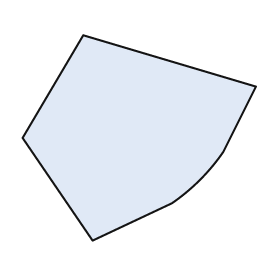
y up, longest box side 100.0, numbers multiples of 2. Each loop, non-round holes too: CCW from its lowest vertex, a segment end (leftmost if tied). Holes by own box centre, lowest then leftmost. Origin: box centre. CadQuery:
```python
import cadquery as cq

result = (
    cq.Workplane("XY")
    .moveTo(-20.0, -44.0)
    .lineTo(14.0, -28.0)
    .threePointArc((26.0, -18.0), (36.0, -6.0))
    .lineTo(50.0, 22.0)
    .lineTo(-24.0, 44.0)
    .lineTo(-50.0, 0.0)
    .close()
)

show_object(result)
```